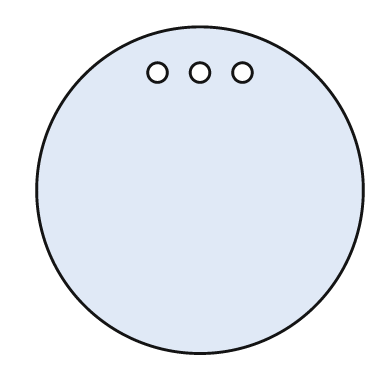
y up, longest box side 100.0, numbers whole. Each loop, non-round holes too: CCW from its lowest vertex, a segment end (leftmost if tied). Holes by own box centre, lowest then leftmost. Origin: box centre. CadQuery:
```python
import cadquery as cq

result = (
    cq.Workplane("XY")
    .moveTo(0.0, 0.0)
    .circle(50.0)
    .moveTo(-13.0, 36.0)
    .circle(3.0)
    .moveTo(0.0, 36.0)
    .circle(3.0)
    .moveTo(13.0, 36.0)
    .circle(3.0)
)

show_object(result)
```